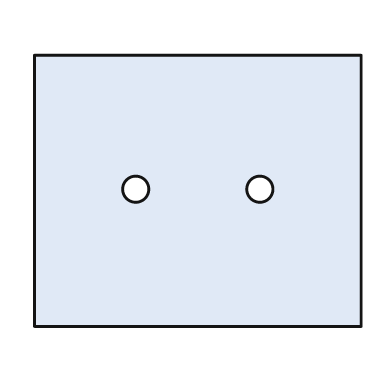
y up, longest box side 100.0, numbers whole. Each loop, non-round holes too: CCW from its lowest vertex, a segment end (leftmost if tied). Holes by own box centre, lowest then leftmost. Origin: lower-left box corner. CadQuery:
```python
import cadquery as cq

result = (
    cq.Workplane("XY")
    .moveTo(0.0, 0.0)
    .lineTo(100.0, 0.0)
    .lineTo(100.0, 83.0)
    .lineTo(0.0, 83.0)
    .close()
    .moveTo(31.0, 42.0)
    .circle(4.0)
    .moveTo(69.0, 42.0)
    .circle(4.0)
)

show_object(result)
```